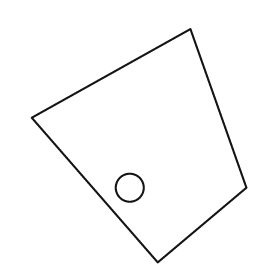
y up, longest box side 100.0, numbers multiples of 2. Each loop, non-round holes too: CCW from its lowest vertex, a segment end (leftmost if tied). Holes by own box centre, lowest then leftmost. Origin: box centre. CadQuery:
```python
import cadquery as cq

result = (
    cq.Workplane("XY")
    .moveTo(8.0, -50.0)
    .lineTo(46.0, -18.0)
    .lineTo(22.0, 50.0)
    .lineTo(-46.0, 12.0)
    .close()
    .moveTo(-4.0, -18.0)
    .circle(6.0)
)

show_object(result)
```